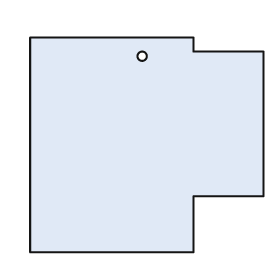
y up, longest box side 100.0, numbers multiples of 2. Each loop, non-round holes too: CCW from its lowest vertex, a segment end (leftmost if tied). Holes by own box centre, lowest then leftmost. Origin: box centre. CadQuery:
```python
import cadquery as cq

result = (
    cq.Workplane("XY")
    .moveTo(-50.0, -46.0)
    .lineTo(20.0, -46.0)
    .lineTo(20.0, -22.0)
    .lineTo(50.0, -22.0)
    .lineTo(50.0, 40.0)
    .lineTo(20.0, 40.0)
    .lineTo(20.0, 46.0)
    .lineTo(-50.0, 46.0)
    .close()
    .moveTo(-2.0, 38.0)
    .circle(2.0)
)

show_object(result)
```